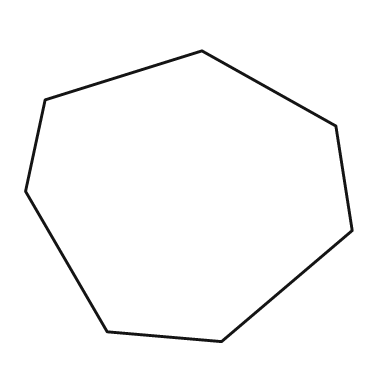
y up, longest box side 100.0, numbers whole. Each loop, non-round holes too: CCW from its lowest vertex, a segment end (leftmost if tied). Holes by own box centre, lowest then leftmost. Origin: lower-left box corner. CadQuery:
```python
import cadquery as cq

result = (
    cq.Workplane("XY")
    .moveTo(60.0, 0.0)
    .lineTo(100.0, 34.0)
    .lineTo(95.0, 66.0)
    .lineTo(54.0, 89.0)
    .lineTo(6.0, 74.0)
    .lineTo(0.0, 46.0)
    .lineTo(25.0, 3.0)
    .close()
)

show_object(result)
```